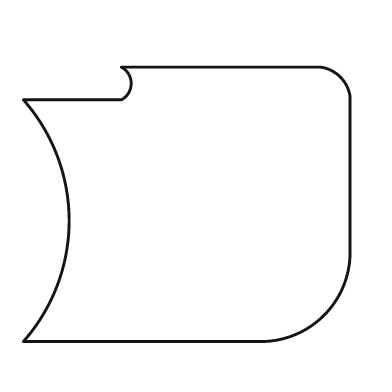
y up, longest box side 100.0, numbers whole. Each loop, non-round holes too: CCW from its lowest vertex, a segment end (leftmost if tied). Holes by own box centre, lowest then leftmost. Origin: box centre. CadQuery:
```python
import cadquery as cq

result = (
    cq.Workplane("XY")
    .moveTo(-50.0, -42.0)
    .lineTo(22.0, -42.0)
    .threePointArc((42.0, -34.0), (50.0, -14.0))
    .lineTo(50.0, 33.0)
    .threePointArc((47.0, 39.0), (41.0, 42.0))
    .lineTo(-20.0, 42.0)
    .threePointArc((-17.0, 37.0), (-20.0, 32.0))
    .lineTo(-50.0, 32.0)
    .threePointArc((-36.0, -5.0), (-50.0, -42.0))
    .close()
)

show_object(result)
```